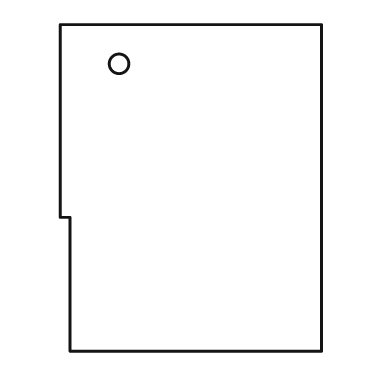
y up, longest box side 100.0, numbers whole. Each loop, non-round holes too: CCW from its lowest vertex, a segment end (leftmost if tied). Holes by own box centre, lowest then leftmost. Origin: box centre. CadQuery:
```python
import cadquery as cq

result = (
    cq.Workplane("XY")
    .moveTo(-37.0, -50.0)
    .lineTo(40.0, -50.0)
    .lineTo(40.0, 50.0)
    .lineTo(-40.0, 50.0)
    .lineTo(-40.0, -9.0)
    .lineTo(-37.0, -9.0)
    .close()
    .moveTo(-22.0, 38.0)
    .circle(3.0)
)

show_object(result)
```